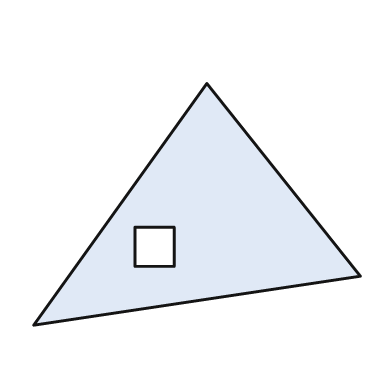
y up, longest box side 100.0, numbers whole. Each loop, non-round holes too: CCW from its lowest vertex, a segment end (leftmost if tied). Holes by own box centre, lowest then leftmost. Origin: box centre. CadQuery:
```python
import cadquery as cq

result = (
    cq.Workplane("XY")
    .moveTo(-50.0, -37.0)
    .lineTo(50.0, -22.0)
    .lineTo(3.0, 37.0)
    .close()
    .moveTo(-19.0, -19.0)
    .lineTo(-7.0, -19.0)
    .lineTo(-7.0, -7.0)
    .lineTo(-19.0, -7.0)
    .close()
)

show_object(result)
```